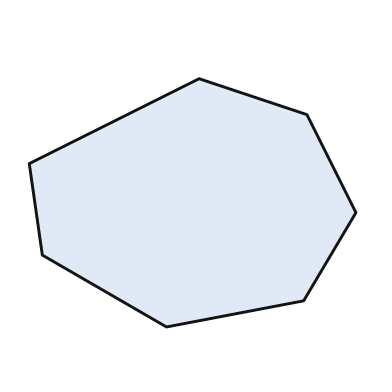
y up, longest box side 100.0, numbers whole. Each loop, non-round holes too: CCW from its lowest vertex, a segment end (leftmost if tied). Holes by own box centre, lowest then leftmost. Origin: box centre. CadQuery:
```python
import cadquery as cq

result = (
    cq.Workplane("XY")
    .moveTo(-8.0, -38.0)
    .lineTo(34.0, -30.0)
    .lineTo(50.0, -3.0)
    .lineTo(35.0, 27.0)
    .lineTo(2.0, 38.0)
    .lineTo(-50.0, 12.0)
    .lineTo(-46.0, -16.0)
    .close()
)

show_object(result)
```